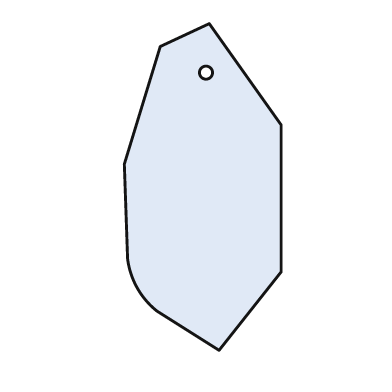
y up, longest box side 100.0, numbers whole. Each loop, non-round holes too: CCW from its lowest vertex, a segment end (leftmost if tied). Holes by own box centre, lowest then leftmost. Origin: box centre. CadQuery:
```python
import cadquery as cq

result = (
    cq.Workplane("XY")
    .moveTo(5.0, -50.0)
    .lineTo(24.0, -26.0)
    .lineTo(24.0, 19.0)
    .lineTo(2.0, 50.0)
    .lineTo(-13.0, 43.0)
    .lineTo(-24.0, 7.0)
    .lineTo(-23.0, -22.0)
    .threePointArc((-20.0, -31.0), (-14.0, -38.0))
    .close()
    .moveTo(1.0, 35.0)
    .circle(2.0)
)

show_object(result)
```